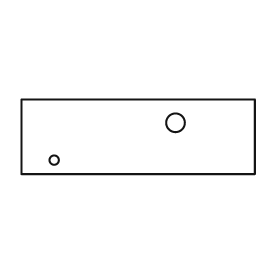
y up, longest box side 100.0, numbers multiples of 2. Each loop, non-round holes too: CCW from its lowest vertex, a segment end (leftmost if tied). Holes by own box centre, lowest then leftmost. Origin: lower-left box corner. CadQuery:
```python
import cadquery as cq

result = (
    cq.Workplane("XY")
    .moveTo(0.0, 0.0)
    .lineTo(100.0, 0.0)
    .lineTo(100.0, 32.0)
    .lineTo(0.0, 32.0)
    .close()
    .moveTo(14.0, 6.0)
    .circle(2.0)
    .moveTo(66.0, 22.0)
    .circle(4.0)
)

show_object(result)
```